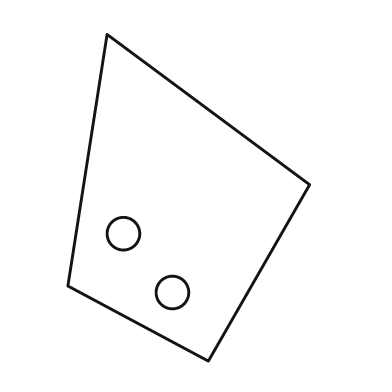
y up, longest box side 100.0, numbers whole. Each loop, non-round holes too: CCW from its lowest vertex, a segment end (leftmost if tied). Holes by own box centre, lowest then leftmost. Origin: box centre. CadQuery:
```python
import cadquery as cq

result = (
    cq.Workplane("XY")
    .moveTo(6.0, -50.0)
    .lineTo(37.0, 4.0)
    .lineTo(-25.0, 50.0)
    .lineTo(-37.0, -27.0)
    .close()
    .moveTo(-5.0, -29.0)
    .circle(5.0)
    .moveTo(-20.0, -11.0)
    .circle(5.0)
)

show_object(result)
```